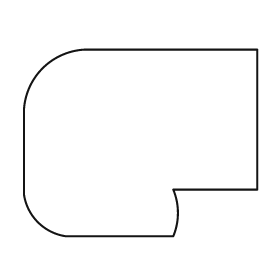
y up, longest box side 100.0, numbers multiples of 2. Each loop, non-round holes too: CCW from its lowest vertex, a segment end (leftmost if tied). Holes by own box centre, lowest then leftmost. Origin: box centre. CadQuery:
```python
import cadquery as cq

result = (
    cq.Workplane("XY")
    .moveTo(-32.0, -40.0)
    .lineTo(14.0, -40.0)
    .threePointArc((16.0, -30.0), (14.0, -20.0))
    .lineTo(50.0, -20.0)
    .lineTo(50.0, 40.0)
    .lineTo(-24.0, 40.0)
    .threePointArc((-42.0, 32.0), (-50.0, 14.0))
    .lineTo(-50.0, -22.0)
    .threePointArc((-44.0, -34.0), (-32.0, -40.0))
    .close()
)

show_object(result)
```